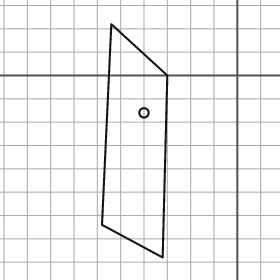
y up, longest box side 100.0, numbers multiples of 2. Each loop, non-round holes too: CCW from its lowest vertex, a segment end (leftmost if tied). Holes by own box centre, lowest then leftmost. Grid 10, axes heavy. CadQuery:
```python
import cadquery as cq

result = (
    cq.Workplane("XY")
    .moveTo(-32.0, -78.0)
    .lineTo(-30.0, 0.0)
    .lineTo(-54.0, 22.0)
    .lineTo(-58.0, -64.0)
    .close()
    .moveTo(-40.0, -16.0)
    .circle(2.0)
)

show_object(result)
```